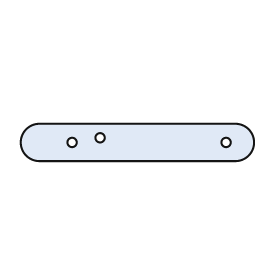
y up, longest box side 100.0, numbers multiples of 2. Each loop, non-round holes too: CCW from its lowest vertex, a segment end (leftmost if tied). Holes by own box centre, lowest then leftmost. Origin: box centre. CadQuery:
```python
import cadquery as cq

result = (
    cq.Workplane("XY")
    .moveTo(-42.0, -8.0)
    .lineTo(42.0, -8.0)
    .threePointArc((50.0, 0.0), (42.0, 8.0))
    .lineTo(-42.0, 8.0)
    .threePointArc((-50.0, 0.0), (-42.0, -8.0))
    .close()
    .moveTo(-28.0, 0.0)
    .circle(2.0)
    .moveTo(38.0, 0.0)
    .circle(2.0)
    .moveTo(-16.0, 2.0)
    .circle(2.0)
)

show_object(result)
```